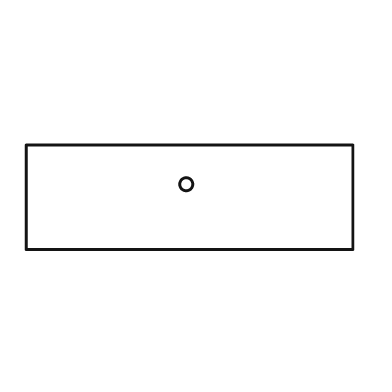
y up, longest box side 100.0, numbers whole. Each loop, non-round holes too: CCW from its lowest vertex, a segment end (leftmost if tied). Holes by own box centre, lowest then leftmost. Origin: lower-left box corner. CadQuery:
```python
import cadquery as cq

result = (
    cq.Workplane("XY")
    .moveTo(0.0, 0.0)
    .lineTo(100.0, 0.0)
    .lineTo(100.0, 32.0)
    .lineTo(0.0, 32.0)
    .close()
    .moveTo(49.0, 20.0)
    .circle(2.0)
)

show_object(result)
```